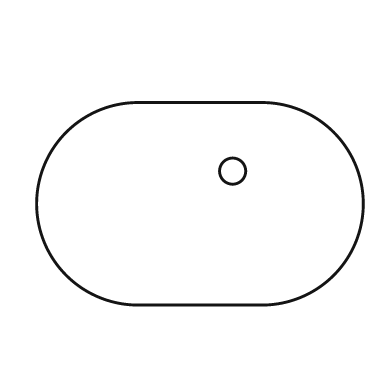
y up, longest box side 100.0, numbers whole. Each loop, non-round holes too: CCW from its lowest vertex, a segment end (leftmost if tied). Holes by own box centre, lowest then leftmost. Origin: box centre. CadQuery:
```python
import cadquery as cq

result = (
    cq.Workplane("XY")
    .moveTo(-19.0, -31.0)
    .lineTo(19.0, -31.0)
    .threePointArc((50.0, 0.0), (19.0, 31.0))
    .lineTo(-19.0, 31.0)
    .threePointArc((-50.0, 0.0), (-19.0, -31.0))
    .close()
    .moveTo(10.0, 10.0)
    .circle(4.0)
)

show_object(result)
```